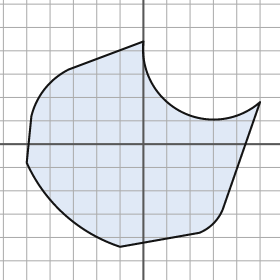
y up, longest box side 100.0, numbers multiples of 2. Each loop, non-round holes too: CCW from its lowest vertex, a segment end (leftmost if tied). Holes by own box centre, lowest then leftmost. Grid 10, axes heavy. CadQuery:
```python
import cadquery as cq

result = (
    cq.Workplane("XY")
    .moveTo(-10.0, -44.0)
    .lineTo(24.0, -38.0)
    .threePointArc((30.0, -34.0), (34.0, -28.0))
    .lineTo(50.0, 18.0)
    .threePointArc((16.0, 14.0), (0.0, 44.0))
    .lineTo(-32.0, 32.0)
    .threePointArc((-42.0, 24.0), (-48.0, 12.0))
    .lineTo(-50.0, -8.0)
    .threePointArc((-34.0, -30.0), (-10.0, -44.0))
    .close()
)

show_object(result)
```